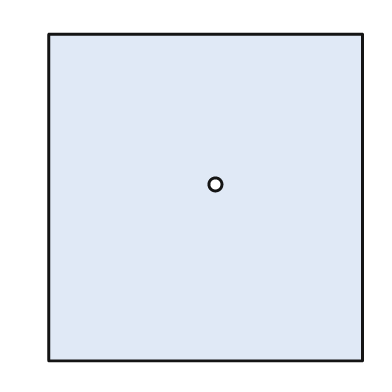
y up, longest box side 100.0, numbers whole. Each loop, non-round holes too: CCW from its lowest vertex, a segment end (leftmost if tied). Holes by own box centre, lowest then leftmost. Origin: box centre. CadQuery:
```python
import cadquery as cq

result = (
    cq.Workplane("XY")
    .moveTo(-48.0, -50.0)
    .lineTo(48.0, -50.0)
    .lineTo(48.0, 50.0)
    .lineTo(-48.0, 50.0)
    .close()
    .moveTo(3.0, 4.0)
    .circle(2.0)
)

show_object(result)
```